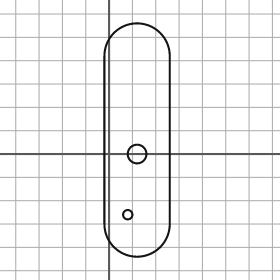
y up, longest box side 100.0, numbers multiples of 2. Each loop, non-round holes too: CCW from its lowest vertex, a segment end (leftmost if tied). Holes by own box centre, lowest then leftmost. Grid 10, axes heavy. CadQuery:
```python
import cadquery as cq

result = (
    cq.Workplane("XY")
    .moveTo(-2.0, -30.0)
    .threePointArc((12.0, -44.0), (26.0, -30.0))
    .lineTo(26.0, 42.0)
    .threePointArc((12.0, 56.0), (-2.0, 42.0))
    .close()
    .moveTo(8.0, -26.0)
    .circle(2.0)
    .moveTo(12.0, 0.0)
    .circle(4.0)
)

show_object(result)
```